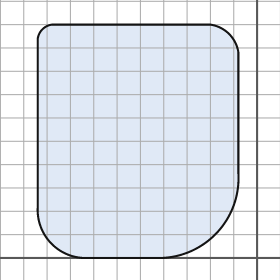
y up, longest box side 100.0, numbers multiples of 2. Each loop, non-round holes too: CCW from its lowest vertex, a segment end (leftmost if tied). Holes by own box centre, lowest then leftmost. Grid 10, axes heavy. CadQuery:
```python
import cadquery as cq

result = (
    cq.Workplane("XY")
    .moveTo(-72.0, 0.0)
    .lineTo(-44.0, 0.0)
    .threePointArc((-18.0, 10.0), (-8.0, 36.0))
    .lineTo(-8.0, 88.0)
    .threePointArc((-12.0, 96.0), (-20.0, 100.0))
    .lineTo(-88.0, 100.0)
    .threePointArc((-92.0, 98.0), (-94.0, 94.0))
    .lineTo(-94.0, 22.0)
    .threePointArc((-88.0, 6.0), (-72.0, 0.0))
    .close()
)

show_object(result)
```